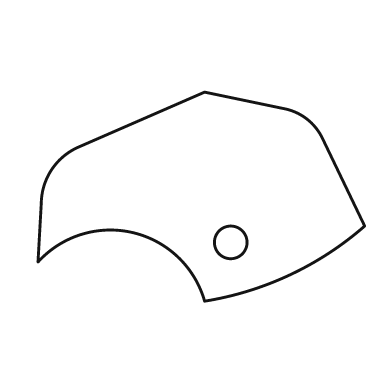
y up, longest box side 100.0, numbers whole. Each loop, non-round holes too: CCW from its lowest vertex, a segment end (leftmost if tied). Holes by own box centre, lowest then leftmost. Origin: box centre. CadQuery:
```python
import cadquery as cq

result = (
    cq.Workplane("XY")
    .moveTo(1.0, -32.0)
    .threePointArc((27.0, -24.0), (50.0, -9.0))
    .lineTo(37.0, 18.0)
    .threePointArc((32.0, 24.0), (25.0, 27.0))
    .lineTo(1.0, 32.0)
    .lineTo(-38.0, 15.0)
    .threePointArc((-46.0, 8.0), (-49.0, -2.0))
    .lineTo(-50.0, -20.0)
    .threePointArc((-21.0, -11.0), (1.0, -32.0))
    .close()
    .moveTo(9.0, -14.0)
    .circle(5.0)
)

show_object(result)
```